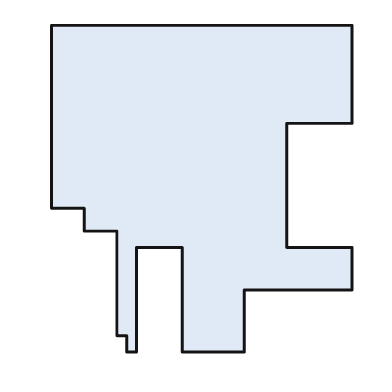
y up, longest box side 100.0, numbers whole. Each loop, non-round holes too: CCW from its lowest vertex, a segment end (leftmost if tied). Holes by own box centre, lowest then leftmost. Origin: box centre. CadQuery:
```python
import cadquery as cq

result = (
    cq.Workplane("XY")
    .moveTo(-23.0, -50.0)
    .lineTo(-20.0, -50.0)
    .lineTo(-20.0, -18.0)
    .lineTo(-6.0, -18.0)
    .lineTo(-6.0, -50.0)
    .lineTo(13.0, -50.0)
    .lineTo(13.0, -31.0)
    .lineTo(46.0, -31.0)
    .lineTo(46.0, -18.0)
    .lineTo(26.0, -18.0)
    .lineTo(26.0, 20.0)
    .lineTo(46.0, 20.0)
    .lineTo(46.0, 50.0)
    .lineTo(-46.0, 50.0)
    .lineTo(-46.0, -6.0)
    .lineTo(-36.0, -6.0)
    .lineTo(-36.0, -13.0)
    .lineTo(-26.0, -13.0)
    .lineTo(-26.0, -45.0)
    .lineTo(-23.0, -45.0)
    .close()
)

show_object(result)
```